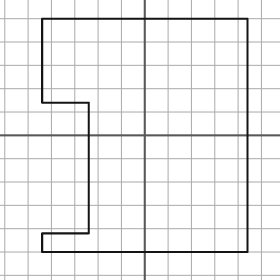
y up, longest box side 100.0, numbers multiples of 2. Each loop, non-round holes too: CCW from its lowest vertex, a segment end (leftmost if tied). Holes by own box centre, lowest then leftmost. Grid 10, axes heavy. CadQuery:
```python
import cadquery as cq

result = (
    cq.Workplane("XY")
    .moveTo(-44.0, -50.0)
    .lineTo(44.0, -50.0)
    .lineTo(44.0, 50.0)
    .lineTo(-44.0, 50.0)
    .lineTo(-44.0, 14.0)
    .lineTo(-24.0, 14.0)
    .lineTo(-24.0, -42.0)
    .lineTo(-44.0, -42.0)
    .close()
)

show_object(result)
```